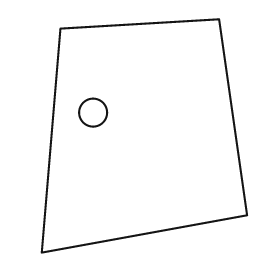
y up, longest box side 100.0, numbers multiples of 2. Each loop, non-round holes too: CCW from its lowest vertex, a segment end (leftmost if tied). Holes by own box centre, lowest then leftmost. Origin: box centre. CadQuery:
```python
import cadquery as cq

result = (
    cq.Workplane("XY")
    .moveTo(-44.0, -50.0)
    .lineTo(44.0, -34.0)
    .lineTo(32.0, 50.0)
    .lineTo(-36.0, 46.0)
    .close()
    .moveTo(-22.0, 10.0)
    .circle(6.0)
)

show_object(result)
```